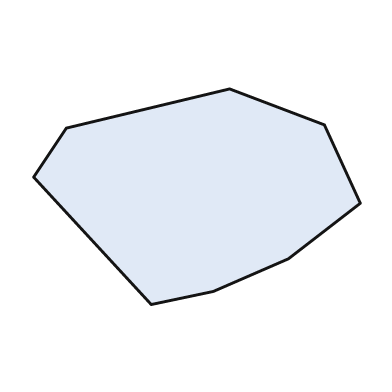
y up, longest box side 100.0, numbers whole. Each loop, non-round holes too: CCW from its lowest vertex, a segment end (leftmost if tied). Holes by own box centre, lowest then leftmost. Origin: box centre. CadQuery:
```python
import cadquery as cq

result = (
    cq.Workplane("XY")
    .moveTo(-14.0, -33.0)
    .lineTo(5.0, -29.0)
    .lineTo(28.0, -19.0)
    .lineTo(50.0, -2.0)
    .lineTo(39.0, 22.0)
    .lineTo(10.0, 33.0)
    .lineTo(-40.0, 21.0)
    .lineTo(-50.0, 6.0)
    .close()
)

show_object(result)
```